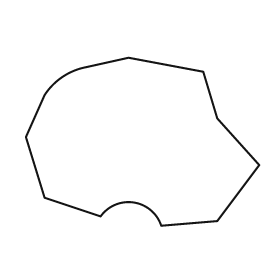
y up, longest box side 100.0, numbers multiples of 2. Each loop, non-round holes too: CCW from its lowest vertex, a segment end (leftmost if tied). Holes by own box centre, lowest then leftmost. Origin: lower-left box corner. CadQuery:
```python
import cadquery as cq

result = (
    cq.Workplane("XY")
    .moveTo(58.0, 0.0)
    .lineTo(82.0, 2.0)
    .lineTo(100.0, 26.0)
    .lineTo(82.0, 46.0)
    .lineTo(76.0, 66.0)
    .lineTo(44.0, 72.0)
    .lineTo(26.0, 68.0)
    .threePointArc((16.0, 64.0), (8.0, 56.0))
    .lineTo(0.0, 38.0)
    .lineTo(8.0, 12.0)
    .lineTo(32.0, 4.0)
    .threePointArc((46.0, 10.0), (58.0, 0.0))
    .close()
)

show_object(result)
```